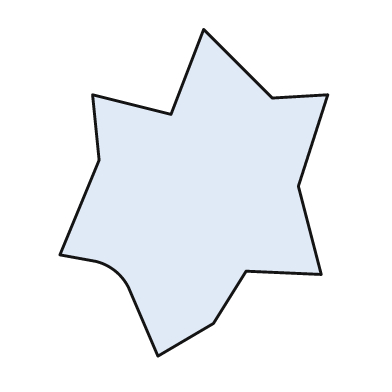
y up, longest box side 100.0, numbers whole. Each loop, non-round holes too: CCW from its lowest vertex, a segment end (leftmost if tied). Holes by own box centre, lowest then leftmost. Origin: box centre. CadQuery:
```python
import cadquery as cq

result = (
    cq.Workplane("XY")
    .moveTo(-11.0, -50.0)
    .lineTo(6.0, -40.0)
    .lineTo(16.0, -24.0)
    .lineTo(39.0, -25.0)
    .lineTo(32.0, 2.0)
    .lineTo(41.0, 30.0)
    .lineTo(24.0, 29.0)
    .lineTo(3.0, 50.0)
    .lineTo(-7.0, 24.0)
    .lineTo(-31.0, 30.0)
    .lineTo(-29.0, 10.0)
    .lineTo(-41.0, -19.0)
    .lineTo(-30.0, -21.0)
    .threePointArc((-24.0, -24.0), (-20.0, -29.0))
    .close()
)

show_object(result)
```